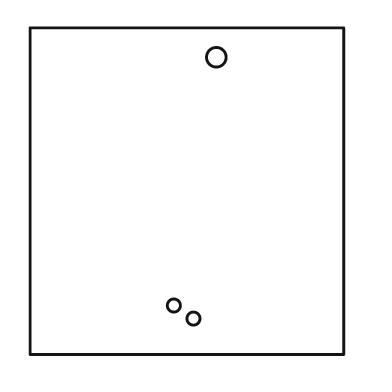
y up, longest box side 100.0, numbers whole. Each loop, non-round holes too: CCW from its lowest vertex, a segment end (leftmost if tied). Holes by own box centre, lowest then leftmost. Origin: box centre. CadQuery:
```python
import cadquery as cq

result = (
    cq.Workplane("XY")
    .moveTo(-48.0, -50.0)
    .lineTo(48.0, -50.0)
    .lineTo(48.0, 50.0)
    .lineTo(-48.0, 50.0)
    .close()
    .moveTo(2.0, -39.0)
    .circle(2.0)
    .moveTo(-4.0, -35.0)
    .circle(2.0)
    .moveTo(9.0, 41.0)
    .circle(3.0)
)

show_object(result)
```